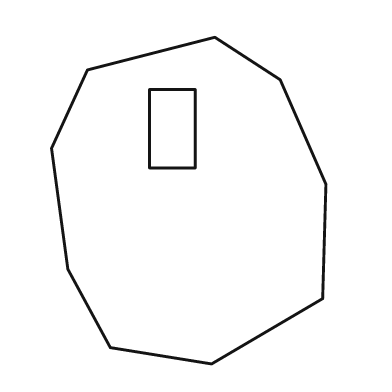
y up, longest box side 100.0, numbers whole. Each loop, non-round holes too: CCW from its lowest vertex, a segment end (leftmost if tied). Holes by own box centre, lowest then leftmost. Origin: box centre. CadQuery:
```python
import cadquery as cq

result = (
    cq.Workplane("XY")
    .moveTo(7.0, -50.0)
    .lineTo(41.0, -30.0)
    .lineTo(42.0, 5.0)
    .lineTo(28.0, 37.0)
    .lineTo(8.0, 50.0)
    .lineTo(-31.0, 40.0)
    .lineTo(-42.0, 16.0)
    .lineTo(-37.0, -21.0)
    .lineTo(-24.0, -45.0)
    .close()
    .moveTo(-12.0, 10.0)
    .lineTo(2.0, 10.0)
    .lineTo(2.0, 34.0)
    .lineTo(-12.0, 34.0)
    .close()
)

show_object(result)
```